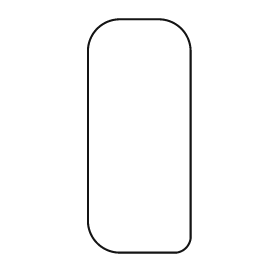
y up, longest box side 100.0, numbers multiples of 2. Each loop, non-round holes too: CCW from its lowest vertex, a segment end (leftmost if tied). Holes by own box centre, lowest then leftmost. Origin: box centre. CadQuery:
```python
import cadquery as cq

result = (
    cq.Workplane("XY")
    .moveTo(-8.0, -50.0)
    .lineTo(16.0, -50.0)
    .threePointArc((20.0, -48.0), (22.0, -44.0))
    .lineTo(22.0, 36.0)
    .threePointArc((18.0, 46.0), (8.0, 50.0))
    .lineTo(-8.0, 50.0)
    .threePointArc((-18.0, 46.0), (-22.0, 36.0))
    .lineTo(-22.0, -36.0)
    .threePointArc((-18.0, -46.0), (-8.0, -50.0))
    .close()
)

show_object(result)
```